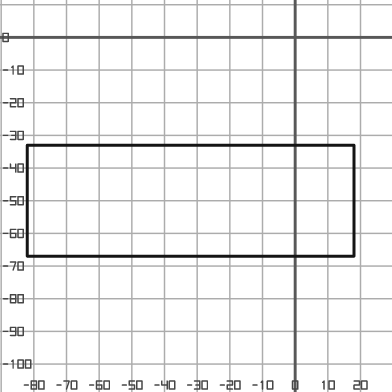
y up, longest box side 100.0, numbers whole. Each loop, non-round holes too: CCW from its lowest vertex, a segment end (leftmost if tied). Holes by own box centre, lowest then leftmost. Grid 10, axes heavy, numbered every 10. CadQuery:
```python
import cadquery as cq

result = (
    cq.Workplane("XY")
    .moveTo(-82.0, -67.0)
    .lineTo(18.0, -67.0)
    .lineTo(18.0, -33.0)
    .lineTo(-82.0, -33.0)
    .close()
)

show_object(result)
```